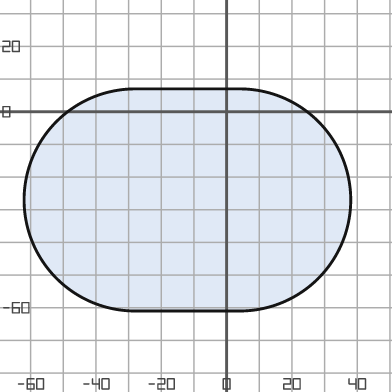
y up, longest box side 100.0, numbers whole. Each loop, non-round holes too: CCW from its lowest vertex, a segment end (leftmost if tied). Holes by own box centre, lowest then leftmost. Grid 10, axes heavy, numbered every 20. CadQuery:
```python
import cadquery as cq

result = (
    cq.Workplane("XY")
    .moveTo(-28.0, -61.0)
    .lineTo(4.0, -61.0)
    .threePointArc((38.0, -27.0), (4.0, 7.0))
    .lineTo(-28.0, 7.0)
    .threePointArc((-62.0, -27.0), (-28.0, -61.0))
    .close()
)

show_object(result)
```